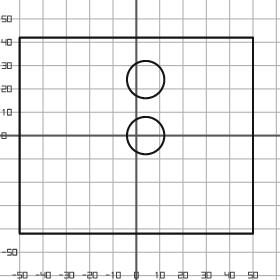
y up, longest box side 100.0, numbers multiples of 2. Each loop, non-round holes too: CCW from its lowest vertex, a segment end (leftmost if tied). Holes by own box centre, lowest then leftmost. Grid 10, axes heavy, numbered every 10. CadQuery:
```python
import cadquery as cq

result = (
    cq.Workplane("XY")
    .moveTo(-50.0, -42.0)
    .lineTo(50.0, -42.0)
    .lineTo(50.0, 42.0)
    .lineTo(-50.0, 42.0)
    .close()
    .moveTo(4.0, 0.0)
    .circle(8.0)
    .moveTo(4.0, 24.0)
    .circle(8.0)
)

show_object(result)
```